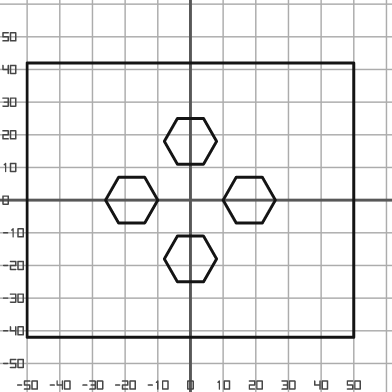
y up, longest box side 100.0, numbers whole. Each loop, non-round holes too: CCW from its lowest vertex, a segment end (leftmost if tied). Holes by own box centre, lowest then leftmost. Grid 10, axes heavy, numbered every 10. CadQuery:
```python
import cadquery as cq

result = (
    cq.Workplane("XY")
    .moveTo(-50.0, -42.0)
    .lineTo(50.0, -42.0)
    .lineTo(50.0, 42.0)
    .lineTo(-50.0, 42.0)
    .close()
    .moveTo(-4.0, -25.0)
    .lineTo(4.0, -25.0)
    .lineTo(8.0, -18.0)
    .lineTo(4.0, -11.0)
    .lineTo(-4.0, -11.0)
    .lineTo(-8.0, -18.0)
    .close()
    .moveTo(-22.0, -7.0)
    .lineTo(-14.0, -7.0)
    .lineTo(-10.0, 0.0)
    .lineTo(-14.0, 7.0)
    .lineTo(-22.0, 7.0)
    .lineTo(-26.0, 0.0)
    .close()
    .moveTo(14.0, -7.0)
    .lineTo(22.0, -7.0)
    .lineTo(26.0, 0.0)
    .lineTo(22.0, 7.0)
    .lineTo(14.0, 7.0)
    .lineTo(10.0, 0.0)
    .close()
    .moveTo(-4.0, 11.0)
    .lineTo(4.0, 11.0)
    .lineTo(8.0, 18.0)
    .lineTo(4.0, 25.0)
    .lineTo(-4.0, 25.0)
    .lineTo(-8.0, 18.0)
    .close()
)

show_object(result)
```